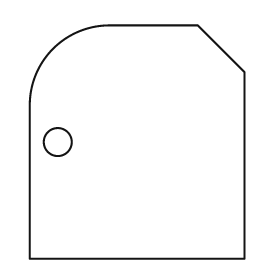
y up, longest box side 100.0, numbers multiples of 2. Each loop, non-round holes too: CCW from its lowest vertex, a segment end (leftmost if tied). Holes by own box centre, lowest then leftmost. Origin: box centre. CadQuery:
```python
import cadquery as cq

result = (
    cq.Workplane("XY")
    .moveTo(-46.0, -50.0)
    .lineTo(46.0, -50.0)
    .lineTo(46.0, 30.0)
    .lineTo(26.0, 50.0)
    .lineTo(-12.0, 50.0)
    .threePointArc((-36.0, 40.0), (-46.0, 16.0))
    .close()
    .moveTo(-34.0, 0.0)
    .circle(6.0)
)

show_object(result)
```